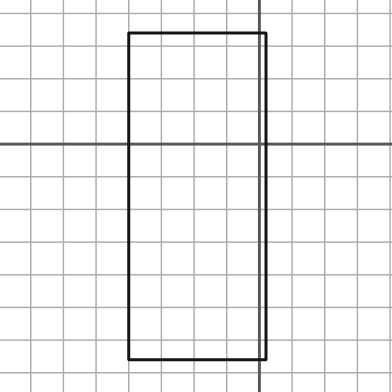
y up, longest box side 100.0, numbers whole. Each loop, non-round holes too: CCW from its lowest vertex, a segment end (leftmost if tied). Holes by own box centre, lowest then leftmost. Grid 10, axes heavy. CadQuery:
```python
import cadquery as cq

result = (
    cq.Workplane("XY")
    .moveTo(-40.0, -66.0)
    .lineTo(2.0, -66.0)
    .lineTo(2.0, 34.0)
    .lineTo(-40.0, 34.0)
    .close()
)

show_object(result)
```